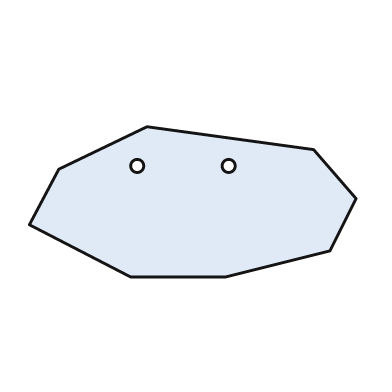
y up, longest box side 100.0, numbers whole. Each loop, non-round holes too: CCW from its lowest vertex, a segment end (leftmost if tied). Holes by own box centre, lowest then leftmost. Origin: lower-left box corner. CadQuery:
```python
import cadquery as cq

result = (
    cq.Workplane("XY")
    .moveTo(31.0, 0.0)
    .lineTo(60.0, 0.0)
    .lineTo(92.0, 8.0)
    .lineTo(100.0, 24.0)
    .lineTo(87.0, 39.0)
    .lineTo(36.0, 46.0)
    .lineTo(9.0, 33.0)
    .lineTo(0.0, 16.0)
    .close()
    .moveTo(33.0, 34.0)
    .circle(2.0)
    .moveTo(61.0, 34.0)
    .circle(2.0)
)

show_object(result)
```